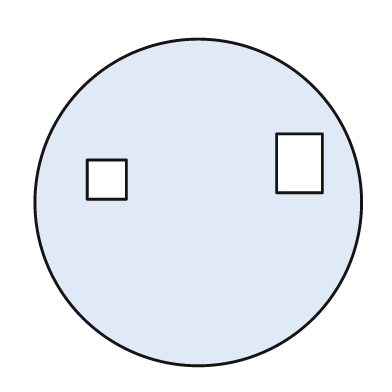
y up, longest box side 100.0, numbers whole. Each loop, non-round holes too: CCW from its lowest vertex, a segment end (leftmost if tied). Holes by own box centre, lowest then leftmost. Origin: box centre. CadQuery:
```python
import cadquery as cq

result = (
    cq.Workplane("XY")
    .moveTo(0.0, 0.0)
    .circle(50.0)
    .moveTo(-34.0, 1.0)
    .lineTo(-22.0, 1.0)
    .lineTo(-22.0, 13.0)
    .lineTo(-34.0, 13.0)
    .close()
    .moveTo(24.0, 3.0)
    .lineTo(38.0, 3.0)
    .lineTo(38.0, 21.0)
    .lineTo(24.0, 21.0)
    .close()
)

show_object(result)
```